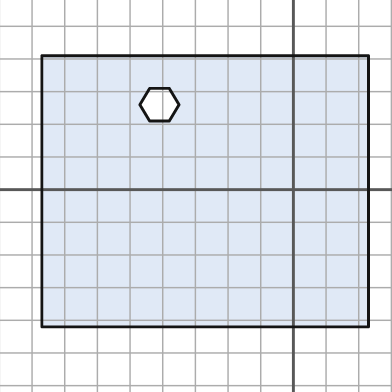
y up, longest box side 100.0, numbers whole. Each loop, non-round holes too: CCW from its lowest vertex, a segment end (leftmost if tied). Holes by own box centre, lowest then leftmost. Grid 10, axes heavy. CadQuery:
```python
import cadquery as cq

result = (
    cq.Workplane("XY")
    .moveTo(-77.0, -42.0)
    .lineTo(23.0, -42.0)
    .lineTo(23.0, 41.0)
    .lineTo(-77.0, 41.0)
    .close()
    .moveTo(-44.0, 21.0)
    .lineTo(-38.0, 21.0)
    .lineTo(-35.0, 26.0)
    .lineTo(-38.0, 31.0)
    .lineTo(-44.0, 31.0)
    .lineTo(-47.0, 26.0)
    .close()
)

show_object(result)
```